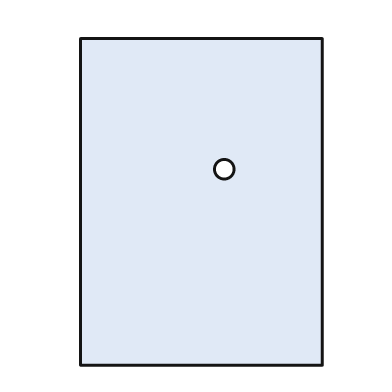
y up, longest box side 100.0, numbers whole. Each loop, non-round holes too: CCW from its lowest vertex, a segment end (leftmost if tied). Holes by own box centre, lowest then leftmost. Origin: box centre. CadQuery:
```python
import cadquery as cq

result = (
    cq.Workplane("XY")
    .moveTo(-37.0, -50.0)
    .lineTo(37.0, -50.0)
    .lineTo(37.0, 50.0)
    .lineTo(-37.0, 50.0)
    .close()
    .moveTo(7.0, 10.0)
    .circle(3.0)
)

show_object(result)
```